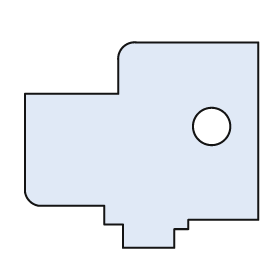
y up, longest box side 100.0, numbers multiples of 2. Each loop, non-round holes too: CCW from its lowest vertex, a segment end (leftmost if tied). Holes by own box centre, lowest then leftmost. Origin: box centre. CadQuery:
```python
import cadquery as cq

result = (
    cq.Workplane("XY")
    .moveTo(-8.0, -44.0)
    .lineTo(14.0, -44.0)
    .lineTo(14.0, -36.0)
    .lineTo(20.0, -36.0)
    .lineTo(20.0, -32.0)
    .lineTo(50.0, -32.0)
    .lineTo(50.0, 44.0)
    .lineTo(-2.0, 44.0)
    .threePointArc((-8.0, 42.0), (-10.0, 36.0))
    .lineTo(-10.0, 22.0)
    .lineTo(-50.0, 22.0)
    .lineTo(-50.0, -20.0)
    .threePointArc((-48.0, -24.0), (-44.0, -26.0))
    .lineTo(-16.0, -26.0)
    .lineTo(-16.0, -34.0)
    .lineTo(-8.0, -34.0)
    .close()
    .moveTo(30.0, 8.0)
    .circle(8.0)
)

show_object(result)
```